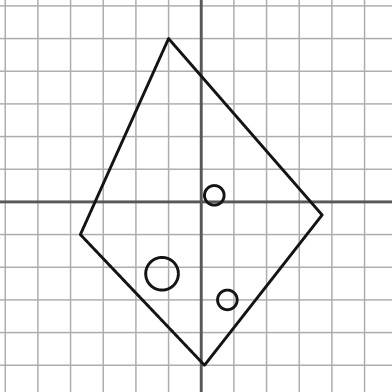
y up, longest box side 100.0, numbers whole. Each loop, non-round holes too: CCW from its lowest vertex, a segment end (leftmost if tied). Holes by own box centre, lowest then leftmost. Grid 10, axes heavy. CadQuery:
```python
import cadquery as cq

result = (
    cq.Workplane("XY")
    .moveTo(1.0, -50.0)
    .lineTo(37.0, -4.0)
    .lineTo(-10.0, 50.0)
    .lineTo(-37.0, -10.0)
    .close()
    .moveTo(8.0, -30.0)
    .circle(3.0)
    .moveTo(-12.0, -22.0)
    .circle(5.0)
    .moveTo(4.0, 2.0)
    .circle(3.0)
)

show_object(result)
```